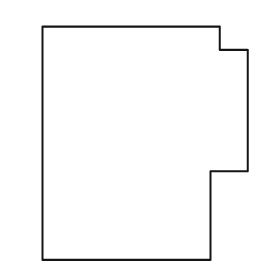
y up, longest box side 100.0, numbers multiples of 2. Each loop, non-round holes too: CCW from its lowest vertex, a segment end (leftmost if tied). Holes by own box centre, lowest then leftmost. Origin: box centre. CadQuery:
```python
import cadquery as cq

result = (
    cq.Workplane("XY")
    .moveTo(-44.0, -50.0)
    .lineTo(28.0, -50.0)
    .lineTo(28.0, -12.0)
    .lineTo(44.0, -12.0)
    .lineTo(44.0, 40.0)
    .lineTo(32.0, 40.0)
    .lineTo(32.0, 50.0)
    .lineTo(-44.0, 50.0)
    .close()
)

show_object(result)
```